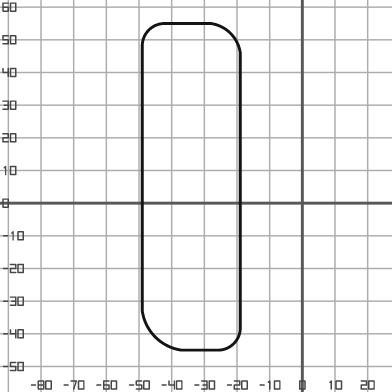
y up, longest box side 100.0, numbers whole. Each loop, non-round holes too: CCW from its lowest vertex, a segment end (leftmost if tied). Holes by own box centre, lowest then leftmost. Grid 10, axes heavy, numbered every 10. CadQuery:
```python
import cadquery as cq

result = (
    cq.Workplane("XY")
    .moveTo(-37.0, -45.0)
    .lineTo(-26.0, -45.0)
    .threePointArc((-21.0, -43.0), (-19.0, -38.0))
    .lineTo(-19.0, 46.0)
    .threePointArc((-22.0, 52.0), (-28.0, 55.0))
    .lineTo(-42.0, 55.0)
    .threePointArc((-47.0, 53.0), (-49.0, 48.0))
    .lineTo(-49.0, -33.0)
    .threePointArc((-45.0, -41.0), (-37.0, -45.0))
    .close()
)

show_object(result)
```